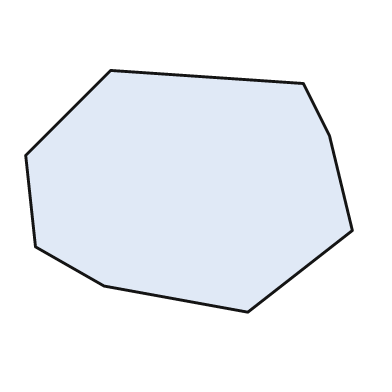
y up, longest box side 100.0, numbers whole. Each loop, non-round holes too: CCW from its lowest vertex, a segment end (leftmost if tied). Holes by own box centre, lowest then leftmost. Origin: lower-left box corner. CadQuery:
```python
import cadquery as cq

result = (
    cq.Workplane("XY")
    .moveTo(68.0, 0.0)
    .lineTo(100.0, 25.0)
    .lineTo(93.0, 54.0)
    .lineTo(85.0, 70.0)
    .lineTo(26.0, 74.0)
    .lineTo(0.0, 48.0)
    .lineTo(3.0, 20.0)
    .lineTo(24.0, 8.0)
    .close()
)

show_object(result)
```